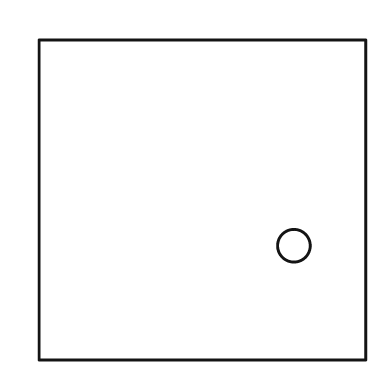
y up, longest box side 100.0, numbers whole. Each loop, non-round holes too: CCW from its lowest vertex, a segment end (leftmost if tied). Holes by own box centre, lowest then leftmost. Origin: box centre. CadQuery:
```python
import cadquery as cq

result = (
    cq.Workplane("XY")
    .moveTo(-50.0, -49.0)
    .lineTo(50.0, -49.0)
    .lineTo(50.0, 49.0)
    .lineTo(-50.0, 49.0)
    .close()
    .moveTo(28.0, -14.0)
    .circle(5.0)
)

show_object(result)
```